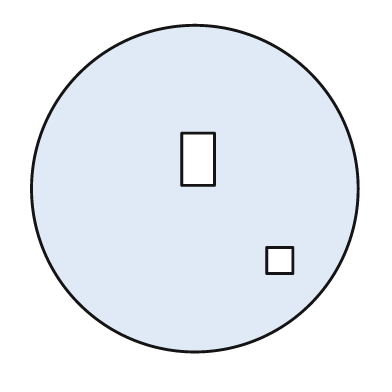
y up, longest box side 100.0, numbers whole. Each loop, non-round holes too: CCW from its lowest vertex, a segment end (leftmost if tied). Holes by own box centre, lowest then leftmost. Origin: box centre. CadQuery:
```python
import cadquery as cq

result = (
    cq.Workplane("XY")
    .moveTo(0.0, 0.0)
    .circle(50.0)
    .moveTo(22.0, -26.0)
    .lineTo(30.0, -26.0)
    .lineTo(30.0, -18.0)
    .lineTo(22.0, -18.0)
    .close()
    .moveTo(-4.0, 1.0)
    .lineTo(6.0, 1.0)
    .lineTo(6.0, 17.0)
    .lineTo(-4.0, 17.0)
    .close()
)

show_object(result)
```